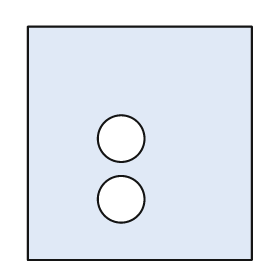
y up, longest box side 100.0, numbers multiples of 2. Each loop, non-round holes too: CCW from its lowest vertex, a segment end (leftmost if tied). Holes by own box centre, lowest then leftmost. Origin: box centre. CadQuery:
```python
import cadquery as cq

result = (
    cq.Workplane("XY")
    .moveTo(-48.0, -50.0)
    .lineTo(48.0, -50.0)
    .lineTo(48.0, 50.0)
    .lineTo(-48.0, 50.0)
    .close()
    .moveTo(-8.0, -24.0)
    .circle(10.0)
    .moveTo(-8.0, 2.0)
    .circle(10.0)
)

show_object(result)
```